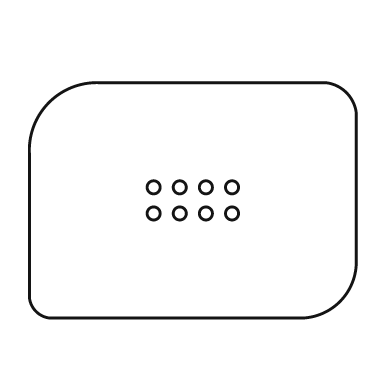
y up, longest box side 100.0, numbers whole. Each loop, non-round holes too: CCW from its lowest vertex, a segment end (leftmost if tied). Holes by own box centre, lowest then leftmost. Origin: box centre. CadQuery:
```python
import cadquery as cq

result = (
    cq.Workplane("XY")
    .moveTo(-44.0, -36.0)
    .lineTo(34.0, -36.0)
    .threePointArc((45.0, -31.0), (50.0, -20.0))
    .lineTo(50.0, 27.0)
    .threePointArc((47.0, 33.0), (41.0, 36.0))
    .lineTo(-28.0, 36.0)
    .threePointArc((-44.0, 30.0), (-50.0, 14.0))
    .lineTo(-50.0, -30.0)
    .threePointArc((-48.0, -34.0), (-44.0, -36.0))
    .close()
    .moveTo(-12.0, -4.0)
    .circle(2.0)
    .moveTo(-4.0, -4.0)
    .circle(2.0)
    .moveTo(4.0, -4.0)
    .circle(2.0)
    .moveTo(12.0, -4.0)
    .circle(2.0)
    .moveTo(-12.0, 4.0)
    .circle(2.0)
    .moveTo(-4.0, 4.0)
    .circle(2.0)
    .moveTo(4.0, 4.0)
    .circle(2.0)
    .moveTo(12.0, 4.0)
    .circle(2.0)
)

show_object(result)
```